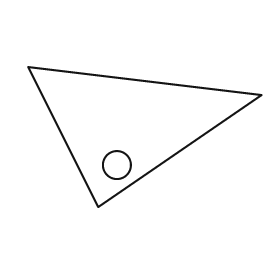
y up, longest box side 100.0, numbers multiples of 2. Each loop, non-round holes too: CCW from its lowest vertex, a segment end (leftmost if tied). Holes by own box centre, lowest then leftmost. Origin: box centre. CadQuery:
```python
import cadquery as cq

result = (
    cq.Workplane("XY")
    .moveTo(-20.0, -30.0)
    .lineTo(50.0, 18.0)
    .lineTo(-50.0, 30.0)
    .close()
    .moveTo(-12.0, -12.0)
    .circle(6.0)
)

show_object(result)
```